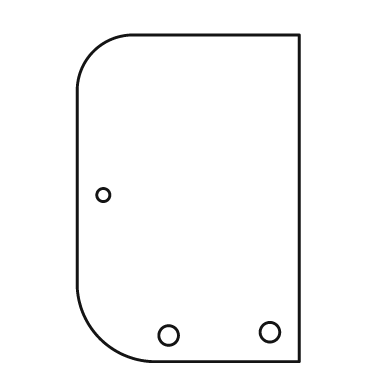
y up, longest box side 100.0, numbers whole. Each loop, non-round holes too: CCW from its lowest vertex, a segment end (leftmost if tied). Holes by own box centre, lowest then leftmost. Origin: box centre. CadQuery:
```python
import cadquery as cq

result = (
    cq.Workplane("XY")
    .moveTo(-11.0, -50.0)
    .lineTo(34.0, -50.0)
    .lineTo(34.0, 50.0)
    .lineTo(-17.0, 50.0)
    .threePointArc((-29.0, 45.0), (-34.0, 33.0))
    .lineTo(-34.0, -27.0)
    .threePointArc((-27.0, -43.0), (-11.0, -50.0))
    .close()
    .moveTo(-6.0, -42.0)
    .circle(3.0)
    .moveTo(25.0, -41.0)
    .circle(3.0)
    .moveTo(-26.0, 1.0)
    .circle(2.0)
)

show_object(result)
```